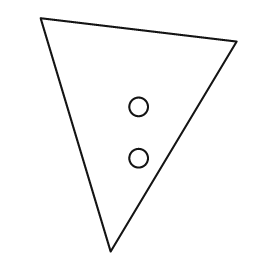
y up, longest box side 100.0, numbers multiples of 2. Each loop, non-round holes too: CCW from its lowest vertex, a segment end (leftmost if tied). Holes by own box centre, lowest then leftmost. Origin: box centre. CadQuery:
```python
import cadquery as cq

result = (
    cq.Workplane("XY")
    .moveTo(-12.0, -50.0)
    .lineTo(42.0, 40.0)
    .lineTo(-42.0, 50.0)
    .close()
    .moveTo(0.0, -10.0)
    .circle(4.0)
    .moveTo(0.0, 12.0)
    .circle(4.0)
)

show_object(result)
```